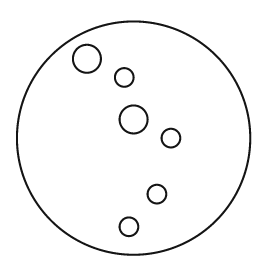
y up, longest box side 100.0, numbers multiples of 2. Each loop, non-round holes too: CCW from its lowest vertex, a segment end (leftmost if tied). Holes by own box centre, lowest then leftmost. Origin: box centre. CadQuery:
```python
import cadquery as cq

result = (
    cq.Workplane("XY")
    .moveTo(0.0, 0.0)
    .circle(50.0)
    .moveTo(-2.0, -38.0)
    .circle(4.0)
    .moveTo(10.0, -24.0)
    .circle(4.0)
    .moveTo(16.0, 0.0)
    .circle(4.0)
    .moveTo(0.0, 8.0)
    .circle(6.0)
    .moveTo(-4.0, 26.0)
    .circle(4.0)
    .moveTo(-20.0, 34.0)
    .circle(6.0)
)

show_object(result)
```